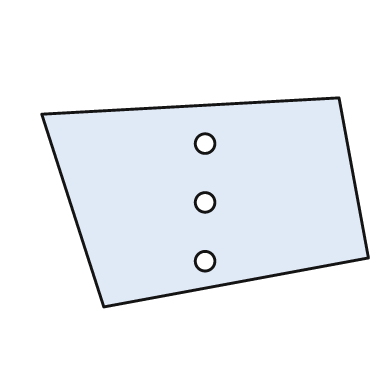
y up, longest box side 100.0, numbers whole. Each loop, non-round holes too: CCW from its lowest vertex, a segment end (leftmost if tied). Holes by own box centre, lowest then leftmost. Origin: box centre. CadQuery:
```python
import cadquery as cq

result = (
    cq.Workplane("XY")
    .moveTo(-31.0, -32.0)
    .lineTo(50.0, -17.0)
    .lineTo(41.0, 32.0)
    .lineTo(-50.0, 27.0)
    .close()
    .moveTo(0.0, -18.0)
    .circle(3.0)
    .moveTo(0.0, 0.0)
    .circle(3.0)
    .moveTo(0.0, 18.0)
    .circle(3.0)
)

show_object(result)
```